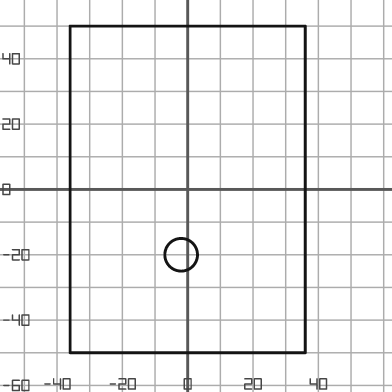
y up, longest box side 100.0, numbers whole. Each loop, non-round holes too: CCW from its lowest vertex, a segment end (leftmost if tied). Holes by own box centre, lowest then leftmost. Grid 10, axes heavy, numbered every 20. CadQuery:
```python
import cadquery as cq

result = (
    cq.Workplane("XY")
    .moveTo(-36.0, -50.0)
    .lineTo(36.0, -50.0)
    .lineTo(36.0, 50.0)
    .lineTo(-36.0, 50.0)
    .close()
    .moveTo(-2.0, -20.0)
    .circle(5.0)
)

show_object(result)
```